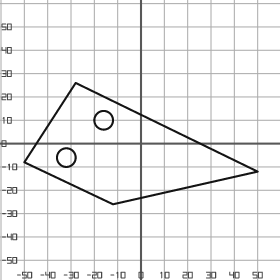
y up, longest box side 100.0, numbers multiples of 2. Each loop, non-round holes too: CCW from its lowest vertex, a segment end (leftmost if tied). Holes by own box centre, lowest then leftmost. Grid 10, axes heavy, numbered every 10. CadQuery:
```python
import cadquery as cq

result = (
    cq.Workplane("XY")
    .moveTo(-12.0, -26.0)
    .lineTo(50.0, -12.0)
    .lineTo(-28.0, 26.0)
    .lineTo(-50.0, -8.0)
    .close()
    .moveTo(-32.0, -6.0)
    .circle(4.0)
    .moveTo(-16.0, 10.0)
    .circle(4.0)
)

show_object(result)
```